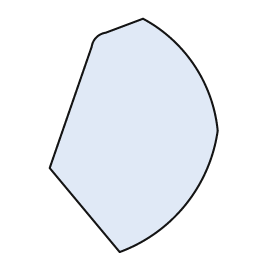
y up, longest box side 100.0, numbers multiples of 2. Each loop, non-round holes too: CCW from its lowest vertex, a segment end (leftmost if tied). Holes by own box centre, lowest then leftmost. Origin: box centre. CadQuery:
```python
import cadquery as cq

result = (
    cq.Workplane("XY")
    .moveTo(-6.0, -50.0)
    .threePointArc((22.0, -30.0), (36.0, 2.0))
    .threePointArc((26.0, 30.0), (4.0, 50.0))
    .lineTo(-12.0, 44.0)
    .threePointArc((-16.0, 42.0), (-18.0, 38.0))
    .lineTo(-36.0, -14.0)
    .close()
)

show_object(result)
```